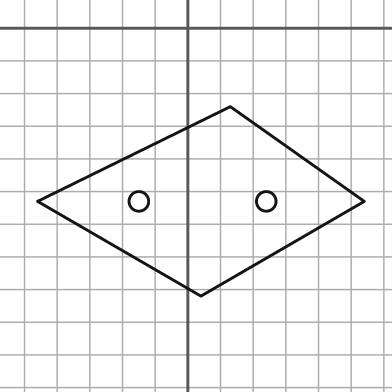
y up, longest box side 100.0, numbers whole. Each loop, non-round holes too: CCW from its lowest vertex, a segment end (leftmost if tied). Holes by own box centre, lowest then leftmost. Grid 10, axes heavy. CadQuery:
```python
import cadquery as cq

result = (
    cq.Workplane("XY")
    .moveTo(4.0, -82.0)
    .lineTo(54.0, -53.0)
    .lineTo(13.0, -24.0)
    .lineTo(-46.0, -53.0)
    .close()
    .moveTo(-15.0, -53.0)
    .circle(3.0)
    .moveTo(24.0, -53.0)
    .circle(3.0)
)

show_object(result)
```